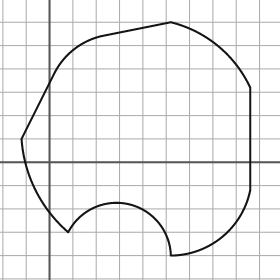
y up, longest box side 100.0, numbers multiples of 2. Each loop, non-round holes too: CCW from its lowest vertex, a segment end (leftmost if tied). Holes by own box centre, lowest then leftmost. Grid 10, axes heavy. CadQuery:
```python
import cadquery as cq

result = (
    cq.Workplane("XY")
    .moveTo(52.0, -40.0)
    .threePointArc((74.0, -32.0), (86.0, -12.0))
    .lineTo(86.0, 32.0)
    .threePointArc((72.0, 50.0), (52.0, 60.0))
    .lineTo(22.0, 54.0)
    .threePointArc((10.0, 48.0), (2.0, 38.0))
    .lineTo(-12.0, 10.0)
    .threePointArc((-6.0, -12.0), (8.0, -30.0))
    .threePointArc((34.0, -18.0), (52.0, -40.0))
    .close()
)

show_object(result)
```